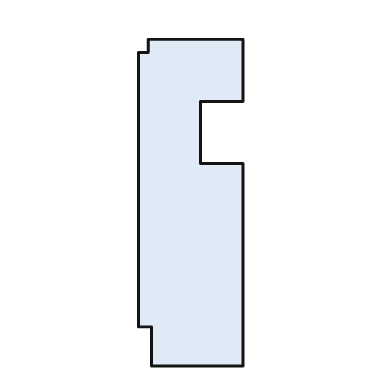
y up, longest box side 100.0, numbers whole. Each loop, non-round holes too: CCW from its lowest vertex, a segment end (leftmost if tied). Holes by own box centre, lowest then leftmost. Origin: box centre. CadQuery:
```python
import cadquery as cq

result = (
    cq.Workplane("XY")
    .moveTo(-12.0, -50.0)
    .lineTo(16.0, -50.0)
    .lineTo(16.0, 12.0)
    .lineTo(3.0, 12.0)
    .lineTo(3.0, 31.0)
    .lineTo(16.0, 31.0)
    .lineTo(16.0, 50.0)
    .lineTo(-13.0, 50.0)
    .lineTo(-13.0, 46.0)
    .lineTo(-16.0, 46.0)
    .lineTo(-16.0, -38.0)
    .lineTo(-12.0, -38.0)
    .close()
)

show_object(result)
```